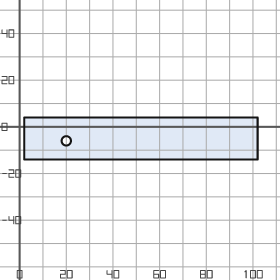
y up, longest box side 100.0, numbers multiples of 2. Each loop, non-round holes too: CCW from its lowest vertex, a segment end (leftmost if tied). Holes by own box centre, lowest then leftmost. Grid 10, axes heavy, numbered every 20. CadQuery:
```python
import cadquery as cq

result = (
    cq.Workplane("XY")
    .moveTo(2.0, -14.0)
    .lineTo(102.0, -14.0)
    .lineTo(102.0, 4.0)
    .lineTo(2.0, 4.0)
    .close()
    .moveTo(20.0, -6.0)
    .circle(2.0)
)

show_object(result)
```